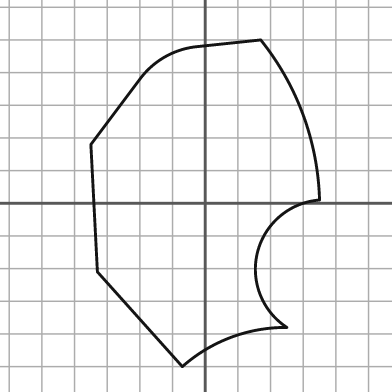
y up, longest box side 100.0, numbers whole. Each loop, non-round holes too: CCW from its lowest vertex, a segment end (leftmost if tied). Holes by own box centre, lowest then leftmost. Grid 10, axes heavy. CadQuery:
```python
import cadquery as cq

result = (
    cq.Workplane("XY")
    .moveTo(-7.0, -50.0)
    .threePointArc((8.0, -41.0), (25.0, -38.0))
    .threePointArc((16.0, -15.0), (35.0, 1.0))
    .threePointArc((30.0, 27.0), (17.0, 50.0))
    .lineTo(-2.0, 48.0)
    .threePointArc((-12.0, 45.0), (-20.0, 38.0))
    .lineTo(-35.0, 18.0)
    .lineTo(-33.0, -21.0)
    .close()
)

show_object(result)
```